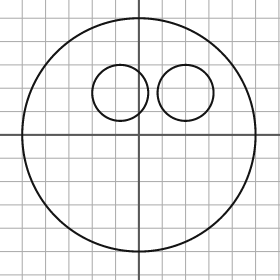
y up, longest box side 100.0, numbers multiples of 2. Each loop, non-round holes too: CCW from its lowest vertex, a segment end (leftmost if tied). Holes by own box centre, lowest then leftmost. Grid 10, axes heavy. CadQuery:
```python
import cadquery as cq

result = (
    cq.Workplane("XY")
    .moveTo(0.0, 0.0)
    .circle(50.0)
    .moveTo(-8.0, 18.0)
    .circle(12.0)
    .moveTo(20.0, 18.0)
    .circle(12.0)
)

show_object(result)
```